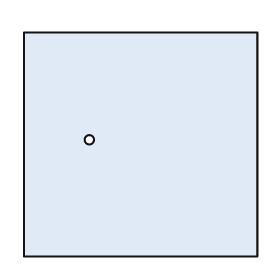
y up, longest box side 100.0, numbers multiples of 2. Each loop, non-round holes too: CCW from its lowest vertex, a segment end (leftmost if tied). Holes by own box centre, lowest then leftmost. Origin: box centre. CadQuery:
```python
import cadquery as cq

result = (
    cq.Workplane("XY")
    .moveTo(-50.0, -48.0)
    .lineTo(50.0, -48.0)
    .lineTo(50.0, 48.0)
    .lineTo(-50.0, 48.0)
    .close()
    .moveTo(-22.0, 2.0)
    .circle(2.0)
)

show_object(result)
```